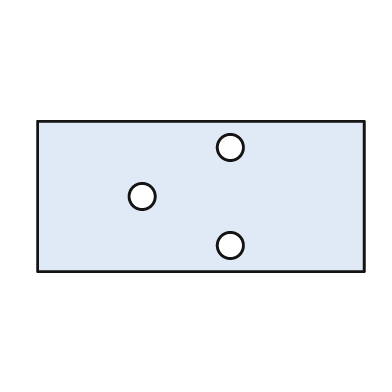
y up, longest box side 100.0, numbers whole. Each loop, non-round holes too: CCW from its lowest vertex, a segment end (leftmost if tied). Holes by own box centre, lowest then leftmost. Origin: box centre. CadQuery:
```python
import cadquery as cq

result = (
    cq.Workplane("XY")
    .moveTo(-50.0, -23.0)
    .lineTo(50.0, -23.0)
    .lineTo(50.0, 23.0)
    .lineTo(-50.0, 23.0)
    .close()
    .moveTo(9.0, -15.0)
    .circle(4.0)
    .moveTo(-18.0, 0.0)
    .circle(4.0)
    .moveTo(9.0, 15.0)
    .circle(4.0)
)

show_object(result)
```